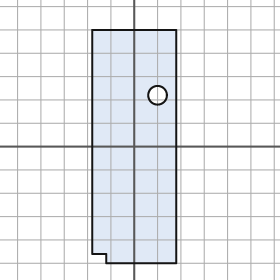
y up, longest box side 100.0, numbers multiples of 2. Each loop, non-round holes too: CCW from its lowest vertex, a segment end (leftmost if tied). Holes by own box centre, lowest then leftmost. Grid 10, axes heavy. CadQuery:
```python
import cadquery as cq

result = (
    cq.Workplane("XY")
    .moveTo(-12.0, -50.0)
    .lineTo(18.0, -50.0)
    .lineTo(18.0, 50.0)
    .lineTo(-18.0, 50.0)
    .lineTo(-18.0, -46.0)
    .lineTo(-12.0, -46.0)
    .close()
    .moveTo(10.0, 22.0)
    .circle(4.0)
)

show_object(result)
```